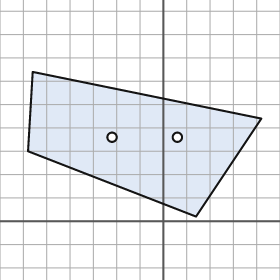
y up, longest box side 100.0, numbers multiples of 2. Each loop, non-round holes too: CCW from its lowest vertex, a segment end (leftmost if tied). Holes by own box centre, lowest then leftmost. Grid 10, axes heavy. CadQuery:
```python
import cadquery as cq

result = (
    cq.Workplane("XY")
    .moveTo(14.0, 2.0)
    .lineTo(42.0, 44.0)
    .lineTo(-56.0, 64.0)
    .lineTo(-58.0, 30.0)
    .close()
    .moveTo(-22.0, 36.0)
    .circle(2.0)
    .moveTo(6.0, 36.0)
    .circle(2.0)
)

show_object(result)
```